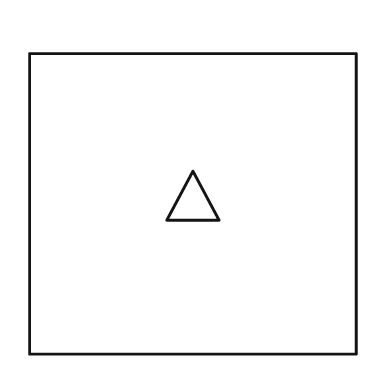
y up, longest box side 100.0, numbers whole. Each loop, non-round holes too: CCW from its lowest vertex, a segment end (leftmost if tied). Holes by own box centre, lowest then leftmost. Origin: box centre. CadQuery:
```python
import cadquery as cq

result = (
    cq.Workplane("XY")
    .moveTo(-50.0, -46.0)
    .lineTo(50.0, -46.0)
    .lineTo(50.0, 46.0)
    .lineTo(-50.0, 46.0)
    .close()
    .moveTo(-8.0, -5.0)
    .lineTo(8.0, -5.0)
    .lineTo(0.0, 10.0)
    .close()
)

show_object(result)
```